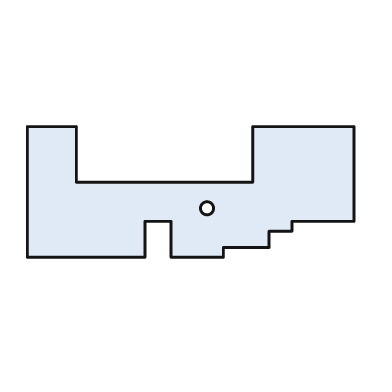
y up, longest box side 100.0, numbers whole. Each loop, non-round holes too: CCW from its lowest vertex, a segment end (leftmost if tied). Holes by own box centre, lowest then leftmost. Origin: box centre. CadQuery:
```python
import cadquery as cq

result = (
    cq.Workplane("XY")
    .moveTo(-50.0, -20.0)
    .lineTo(-14.0, -20.0)
    .lineTo(-14.0, -9.0)
    .lineTo(-6.0, -9.0)
    .lineTo(-6.0, -20.0)
    .lineTo(10.0, -20.0)
    .lineTo(10.0, -17.0)
    .lineTo(24.0, -17.0)
    .lineTo(24.0, -12.0)
    .lineTo(31.0, -12.0)
    .lineTo(31.0, -9.0)
    .lineTo(50.0, -9.0)
    .lineTo(50.0, 20.0)
    .lineTo(19.0, 20.0)
    .lineTo(19.0, 3.0)
    .lineTo(-35.0, 3.0)
    .lineTo(-35.0, 20.0)
    .lineTo(-50.0, 20.0)
    .close()
    .moveTo(5.0, -5.0)
    .circle(2.0)
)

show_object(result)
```